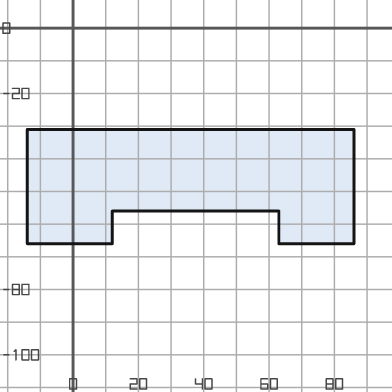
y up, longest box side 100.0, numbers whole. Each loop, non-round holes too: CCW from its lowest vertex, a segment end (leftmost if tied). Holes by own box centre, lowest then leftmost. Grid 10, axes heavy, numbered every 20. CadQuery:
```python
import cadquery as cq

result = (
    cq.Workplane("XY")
    .moveTo(-14.0, -66.0)
    .lineTo(12.0, -66.0)
    .lineTo(12.0, -56.0)
    .lineTo(63.0, -56.0)
    .lineTo(63.0, -66.0)
    .lineTo(86.0, -66.0)
    .lineTo(86.0, -31.0)
    .lineTo(-14.0, -31.0)
    .close()
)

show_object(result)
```